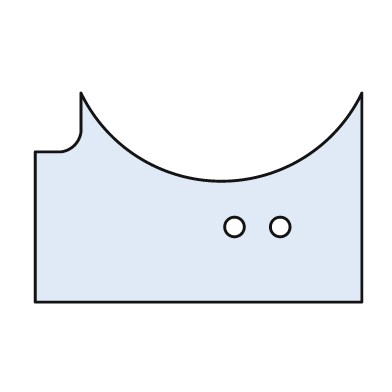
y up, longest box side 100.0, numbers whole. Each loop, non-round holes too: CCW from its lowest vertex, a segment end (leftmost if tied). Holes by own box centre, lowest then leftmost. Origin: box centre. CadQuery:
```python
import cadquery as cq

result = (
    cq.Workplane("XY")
    .moveTo(-50.0, -32.0)
    .lineTo(50.0, -32.0)
    .lineTo(50.0, 32.0)
    .threePointArc((7.0, 5.0), (-36.0, 32.0))
    .lineTo(-36.0, 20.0)
    .threePointArc((-38.0, 16.0), (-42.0, 14.0))
    .lineTo(-50.0, 14.0)
    .close()
    .moveTo(11.0, -9.0)
    .circle(3.0)
    .moveTo(25.0, -9.0)
    .circle(3.0)
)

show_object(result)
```